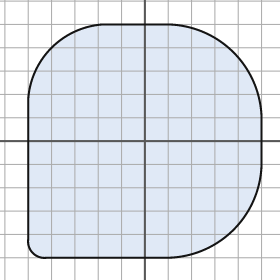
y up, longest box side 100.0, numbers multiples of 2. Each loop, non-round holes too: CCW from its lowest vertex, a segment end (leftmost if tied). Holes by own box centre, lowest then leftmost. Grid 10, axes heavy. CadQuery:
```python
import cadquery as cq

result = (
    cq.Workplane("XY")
    .moveTo(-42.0, -50.0)
    .lineTo(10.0, -50.0)
    .threePointArc((38.0, -38.0), (50.0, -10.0))
    .lineTo(50.0, 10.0)
    .threePointArc((38.0, 38.0), (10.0, 50.0))
    .lineTo(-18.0, 50.0)
    .threePointArc((-40.0, 40.0), (-50.0, 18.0))
    .lineTo(-50.0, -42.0)
    .threePointArc((-48.0, -48.0), (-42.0, -50.0))
    .close()
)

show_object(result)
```